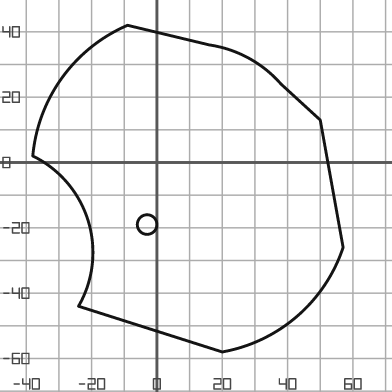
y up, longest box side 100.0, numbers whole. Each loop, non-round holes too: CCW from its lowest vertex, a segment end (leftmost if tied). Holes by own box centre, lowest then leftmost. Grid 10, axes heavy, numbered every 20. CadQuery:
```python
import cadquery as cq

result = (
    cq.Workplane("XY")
    .moveTo(20.0, -58.0)
    .threePointArc((43.0, -47.0), (57.0, -26.0))
    .lineTo(50.0, 13.0)
    .lineTo(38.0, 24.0)
    .threePointArc((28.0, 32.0), (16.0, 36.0))
    .lineTo(-9.0, 42.0)
    .threePointArc((-29.0, 26.0), (-38.0, 2.0))
    .threePointArc((-21.0, -18.0), (-24.0, -44.0))
    .close()
    .moveTo(-3.0, -19.0)
    .circle(3.0)
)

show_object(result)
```